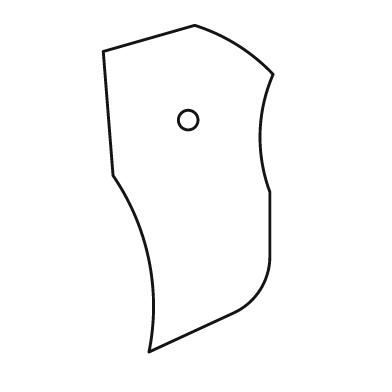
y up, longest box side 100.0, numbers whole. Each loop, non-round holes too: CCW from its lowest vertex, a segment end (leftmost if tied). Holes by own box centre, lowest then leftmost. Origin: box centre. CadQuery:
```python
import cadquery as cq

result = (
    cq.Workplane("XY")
    .moveTo(-12.0, -50.0)
    .lineTo(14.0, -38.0)
    .threePointArc((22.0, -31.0), (25.0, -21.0))
    .lineTo(25.0, -1.0)
    .threePointArc((22.0, 17.0), (26.0, 35.0))
    .threePointArc((15.0, 44.0), (2.0, 50.0))
    .lineTo(-26.0, 42.0)
    .lineTo(-23.0, 4.0)
    .threePointArc((-12.0, -22.0), (-12.0, -50.0))
    .close()
    .moveTo(0.0, 21.0)
    .circle(3.0)
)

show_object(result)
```